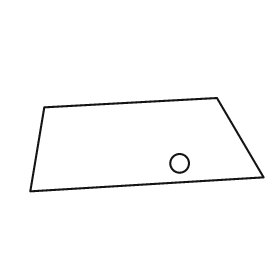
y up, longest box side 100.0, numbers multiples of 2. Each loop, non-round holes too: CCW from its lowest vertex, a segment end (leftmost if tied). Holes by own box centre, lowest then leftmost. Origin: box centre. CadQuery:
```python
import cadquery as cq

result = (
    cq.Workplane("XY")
    .moveTo(-50.0, -20.0)
    .lineTo(50.0, -14.0)
    .lineTo(30.0, 20.0)
    .lineTo(-44.0, 16.0)
    .close()
    .moveTo(14.0, -8.0)
    .circle(4.0)
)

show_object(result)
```